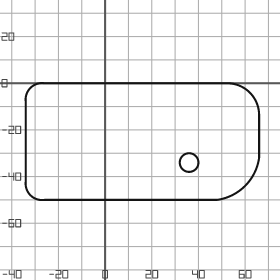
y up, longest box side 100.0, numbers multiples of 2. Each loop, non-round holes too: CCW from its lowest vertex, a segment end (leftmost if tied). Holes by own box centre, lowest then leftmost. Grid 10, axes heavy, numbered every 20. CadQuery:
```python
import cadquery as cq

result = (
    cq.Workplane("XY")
    .moveTo(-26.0, -50.0)
    .lineTo(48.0, -50.0)
    .threePointArc((60.0, -44.0), (66.0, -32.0))
    .lineTo(66.0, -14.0)
    .threePointArc((62.0, -4.0), (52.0, 0.0))
    .lineTo(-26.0, 0.0)
    .threePointArc((-32.0, -2.0), (-34.0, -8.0))
    .lineTo(-34.0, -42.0)
    .threePointArc((-32.0, -48.0), (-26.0, -50.0))
    .close()
    .moveTo(36.0, -34.0)
    .circle(4.0)
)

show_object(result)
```